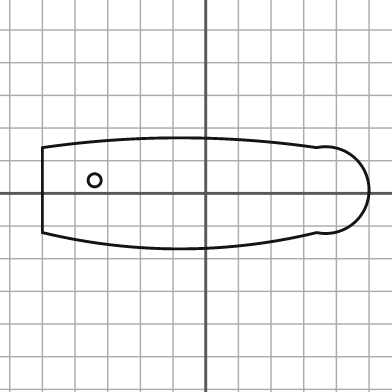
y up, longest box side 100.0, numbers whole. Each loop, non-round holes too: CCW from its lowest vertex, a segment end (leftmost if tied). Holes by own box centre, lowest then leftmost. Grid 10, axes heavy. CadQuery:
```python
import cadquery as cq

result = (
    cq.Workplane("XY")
    .moveTo(-50.0, -12.0)
    .threePointArc((-8.0, -17.0), (34.0, -12.0))
    .threePointArc((50.0, 1.0), (34.0, 14.0))
    .threePointArc((-8.0, 17.0), (-50.0, 14.0))
    .close()
    .moveTo(-34.0, 4.0)
    .circle(2.0)
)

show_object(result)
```